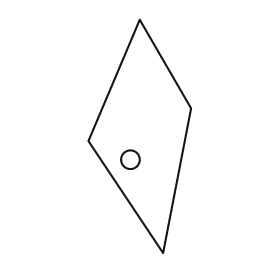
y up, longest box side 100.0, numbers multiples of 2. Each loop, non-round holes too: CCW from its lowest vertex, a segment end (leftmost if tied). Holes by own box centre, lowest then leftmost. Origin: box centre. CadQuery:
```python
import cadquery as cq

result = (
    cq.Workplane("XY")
    .moveTo(10.0, -50.0)
    .lineTo(22.0, 12.0)
    .lineTo(0.0, 50.0)
    .lineTo(-22.0, -2.0)
    .close()
    .moveTo(-4.0, -10.0)
    .circle(4.0)
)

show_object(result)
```